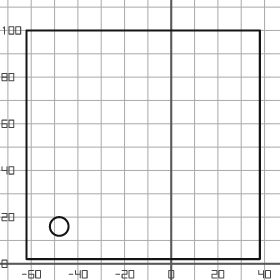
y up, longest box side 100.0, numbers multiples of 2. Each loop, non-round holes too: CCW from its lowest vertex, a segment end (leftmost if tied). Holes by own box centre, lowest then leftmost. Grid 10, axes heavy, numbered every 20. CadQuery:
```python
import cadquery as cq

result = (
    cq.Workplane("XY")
    .moveTo(-62.0, 2.0)
    .lineTo(38.0, 2.0)
    .lineTo(38.0, 100.0)
    .lineTo(-62.0, 100.0)
    .close()
    .moveTo(-48.0, 16.0)
    .circle(4.0)
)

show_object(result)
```